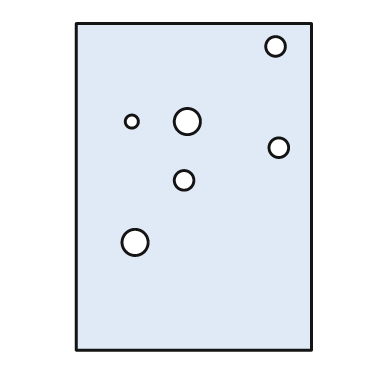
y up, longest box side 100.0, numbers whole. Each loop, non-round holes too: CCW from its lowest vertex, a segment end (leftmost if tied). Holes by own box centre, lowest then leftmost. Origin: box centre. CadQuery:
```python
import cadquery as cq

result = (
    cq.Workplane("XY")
    .moveTo(-36.0, -50.0)
    .lineTo(36.0, -50.0)
    .lineTo(36.0, 50.0)
    .lineTo(-36.0, 50.0)
    .close()
    .moveTo(-18.0, -17.0)
    .circle(4.0)
    .moveTo(-3.0, 2.0)
    .circle(3.0)
    .moveTo(26.0, 12.0)
    .circle(3.0)
    .moveTo(-19.0, 20.0)
    .circle(2.0)
    .moveTo(-2.0, 20.0)
    .circle(4.0)
    .moveTo(25.0, 43.0)
    .circle(3.0)
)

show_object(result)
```